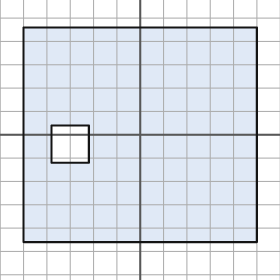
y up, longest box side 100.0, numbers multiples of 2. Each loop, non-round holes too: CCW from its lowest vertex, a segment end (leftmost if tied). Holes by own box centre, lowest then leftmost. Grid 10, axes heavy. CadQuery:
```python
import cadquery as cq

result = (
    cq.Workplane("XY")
    .moveTo(-50.0, -46.0)
    .lineTo(50.0, -46.0)
    .lineTo(50.0, 46.0)
    .lineTo(-50.0, 46.0)
    .close()
    .moveTo(-38.0, -12.0)
    .lineTo(-22.0, -12.0)
    .lineTo(-22.0, 4.0)
    .lineTo(-38.0, 4.0)
    .close()
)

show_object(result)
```